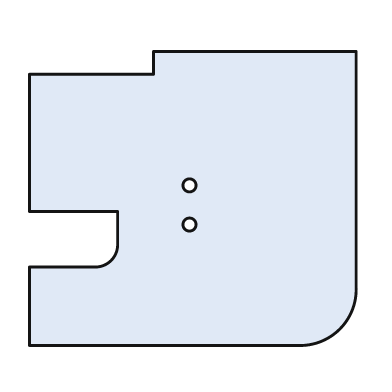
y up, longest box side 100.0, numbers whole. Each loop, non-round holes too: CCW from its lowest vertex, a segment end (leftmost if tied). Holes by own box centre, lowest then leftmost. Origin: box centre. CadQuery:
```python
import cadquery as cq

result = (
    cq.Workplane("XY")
    .moveTo(-50.0, -45.0)
    .lineTo(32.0, -45.0)
    .threePointArc((45.0, -40.0), (50.0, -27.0))
    .lineTo(50.0, 45.0)
    .lineTo(-12.0, 45.0)
    .lineTo(-12.0, 38.0)
    .lineTo(-50.0, 38.0)
    .lineTo(-50.0, -4.0)
    .lineTo(-23.0, -4.0)
    .lineTo(-23.0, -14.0)
    .threePointArc((-25.0, -19.0), (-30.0, -21.0))
    .lineTo(-50.0, -21.0)
    .close()
    .moveTo(-1.0, -8.0)
    .circle(2.0)
    .moveTo(-1.0, 4.0)
    .circle(2.0)
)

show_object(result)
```